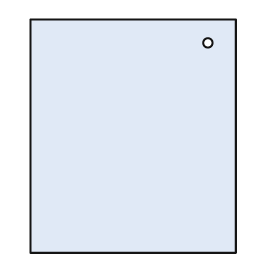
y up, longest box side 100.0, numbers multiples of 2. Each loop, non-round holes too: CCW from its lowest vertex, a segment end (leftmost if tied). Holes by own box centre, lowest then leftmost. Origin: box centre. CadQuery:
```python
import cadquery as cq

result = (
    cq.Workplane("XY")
    .moveTo(-44.0, -50.0)
    .lineTo(44.0, -50.0)
    .lineTo(44.0, 50.0)
    .lineTo(-44.0, 50.0)
    .close()
    .moveTo(32.0, 40.0)
    .circle(2.0)
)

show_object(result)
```